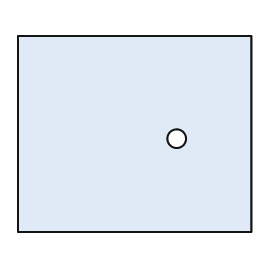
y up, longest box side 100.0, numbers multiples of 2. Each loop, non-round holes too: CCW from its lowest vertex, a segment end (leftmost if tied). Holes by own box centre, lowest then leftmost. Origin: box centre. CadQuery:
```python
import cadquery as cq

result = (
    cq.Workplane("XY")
    .moveTo(-50.0, -42.0)
    .lineTo(50.0, -42.0)
    .lineTo(50.0, 42.0)
    .lineTo(-50.0, 42.0)
    .close()
    .moveTo(18.0, -2.0)
    .circle(4.0)
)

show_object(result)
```